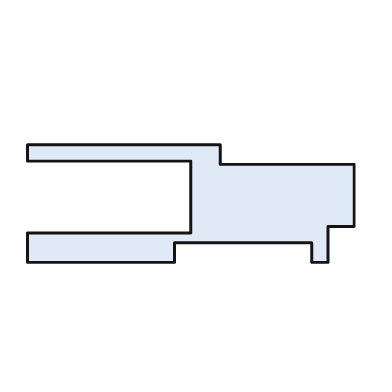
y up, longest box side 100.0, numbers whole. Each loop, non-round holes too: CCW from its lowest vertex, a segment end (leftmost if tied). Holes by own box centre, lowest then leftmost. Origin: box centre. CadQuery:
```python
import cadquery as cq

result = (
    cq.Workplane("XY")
    .moveTo(-50.0, -18.0)
    .lineTo(-5.0, -18.0)
    .lineTo(-5.0, -12.0)
    .lineTo(37.0, -12.0)
    .lineTo(37.0, -18.0)
    .lineTo(42.0, -18.0)
    .lineTo(42.0, -7.0)
    .lineTo(50.0, -7.0)
    .lineTo(50.0, 12.0)
    .lineTo(9.0, 12.0)
    .lineTo(9.0, 18.0)
    .lineTo(-50.0, 18.0)
    .lineTo(-50.0, 13.0)
    .lineTo(0.0, 13.0)
    .lineTo(0.0, -9.0)
    .lineTo(-50.0, -9.0)
    .close()
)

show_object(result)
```